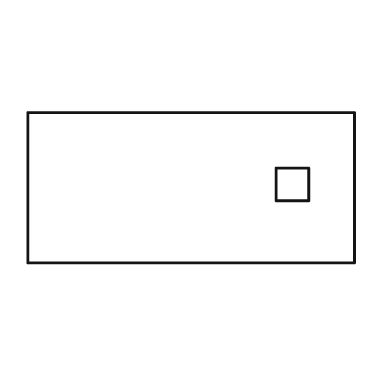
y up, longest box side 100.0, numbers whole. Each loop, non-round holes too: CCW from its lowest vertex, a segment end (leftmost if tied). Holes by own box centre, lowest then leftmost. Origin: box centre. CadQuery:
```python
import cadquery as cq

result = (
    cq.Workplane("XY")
    .moveTo(-50.0, -23.0)
    .lineTo(50.0, -23.0)
    .lineTo(50.0, 23.0)
    .lineTo(-50.0, 23.0)
    .close()
    .moveTo(26.0, -4.0)
    .lineTo(36.0, -4.0)
    .lineTo(36.0, 6.0)
    .lineTo(26.0, 6.0)
    .close()
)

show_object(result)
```